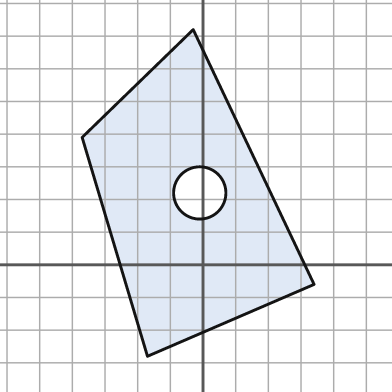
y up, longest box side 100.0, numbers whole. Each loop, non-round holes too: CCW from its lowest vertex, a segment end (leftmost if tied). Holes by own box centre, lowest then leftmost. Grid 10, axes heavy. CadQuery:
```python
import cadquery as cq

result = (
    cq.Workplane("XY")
    .moveTo(-17.0, -28.0)
    .lineTo(34.0, -6.0)
    .lineTo(-3.0, 72.0)
    .lineTo(-37.0, 39.0)
    .close()
    .moveTo(-1.0, 22.0)
    .circle(8.0)
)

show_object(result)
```